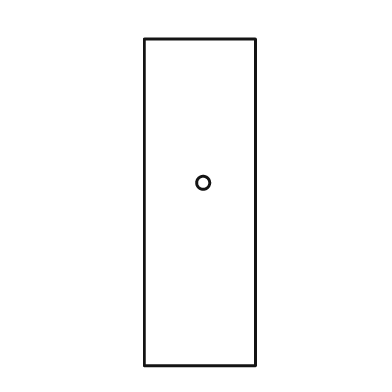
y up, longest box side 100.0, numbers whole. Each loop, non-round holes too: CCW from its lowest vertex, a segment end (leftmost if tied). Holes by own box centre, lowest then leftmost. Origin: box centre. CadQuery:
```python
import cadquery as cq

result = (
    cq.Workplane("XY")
    .moveTo(-17.0, -50.0)
    .lineTo(17.0, -50.0)
    .lineTo(17.0, 50.0)
    .lineTo(-17.0, 50.0)
    .close()
    .moveTo(1.0, 6.0)
    .circle(2.0)
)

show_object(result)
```